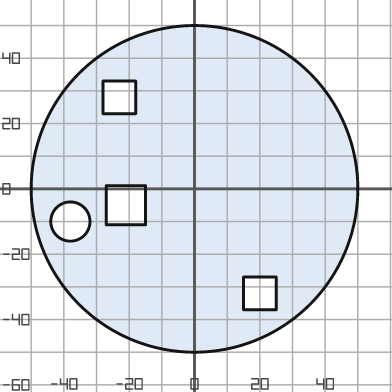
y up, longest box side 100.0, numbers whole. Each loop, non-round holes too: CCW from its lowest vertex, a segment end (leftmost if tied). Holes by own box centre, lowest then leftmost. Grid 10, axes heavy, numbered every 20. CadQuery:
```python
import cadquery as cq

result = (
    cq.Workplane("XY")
    .moveTo(0.0, 0.0)
    .circle(50.0)
    .moveTo(15.0, -37.0)
    .lineTo(25.0, -37.0)
    .lineTo(25.0, -27.0)
    .lineTo(15.0, -27.0)
    .close()
    .moveTo(-38.0, -10.0)
    .circle(6.0)
    .moveTo(-27.0, -11.0)
    .lineTo(-15.0, -11.0)
    .lineTo(-15.0, 1.0)
    .lineTo(-27.0, 1.0)
    .close()
    .moveTo(-28.0, 23.0)
    .lineTo(-18.0, 23.0)
    .lineTo(-18.0, 33.0)
    .lineTo(-28.0, 33.0)
    .close()
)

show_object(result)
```